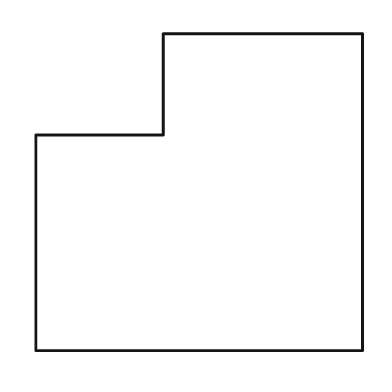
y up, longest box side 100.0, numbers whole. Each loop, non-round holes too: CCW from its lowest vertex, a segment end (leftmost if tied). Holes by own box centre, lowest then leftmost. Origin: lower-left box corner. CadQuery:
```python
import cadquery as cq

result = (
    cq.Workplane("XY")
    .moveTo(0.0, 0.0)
    .lineTo(100.0, 0.0)
    .lineTo(100.0, 97.0)
    .lineTo(39.0, 97.0)
    .lineTo(39.0, 66.0)
    .lineTo(0.0, 66.0)
    .close()
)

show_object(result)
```